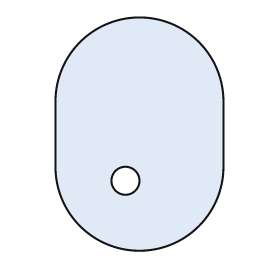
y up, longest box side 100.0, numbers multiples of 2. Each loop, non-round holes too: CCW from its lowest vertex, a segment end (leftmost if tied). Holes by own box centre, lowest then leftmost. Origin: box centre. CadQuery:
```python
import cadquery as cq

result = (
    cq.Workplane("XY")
    .moveTo(-36.0, -14.0)
    .threePointArc((0.0, -50.0), (36.0, -14.0))
    .lineTo(36.0, 14.0)
    .threePointArc((0.0, 50.0), (-36.0, 14.0))
    .close()
    .moveTo(-6.0, -20.0)
    .circle(6.0)
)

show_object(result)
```